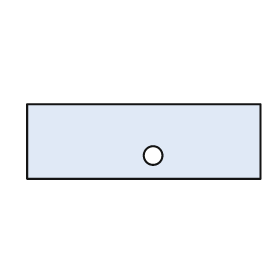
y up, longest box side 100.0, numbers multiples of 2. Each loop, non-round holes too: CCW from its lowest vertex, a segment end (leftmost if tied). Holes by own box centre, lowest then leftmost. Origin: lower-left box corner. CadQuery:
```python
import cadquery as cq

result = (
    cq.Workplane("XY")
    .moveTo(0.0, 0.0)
    .lineTo(100.0, 0.0)
    .lineTo(100.0, 32.0)
    .lineTo(0.0, 32.0)
    .close()
    .moveTo(54.0, 10.0)
    .circle(4.0)
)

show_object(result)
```